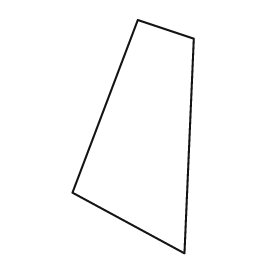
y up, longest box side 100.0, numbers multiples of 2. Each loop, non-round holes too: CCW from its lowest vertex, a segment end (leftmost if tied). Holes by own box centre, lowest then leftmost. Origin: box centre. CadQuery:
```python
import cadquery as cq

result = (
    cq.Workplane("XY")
    .moveTo(22.0, -50.0)
    .lineTo(26.0, 42.0)
    .lineTo(2.0, 50.0)
    .lineTo(-26.0, -24.0)
    .close()
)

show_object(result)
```